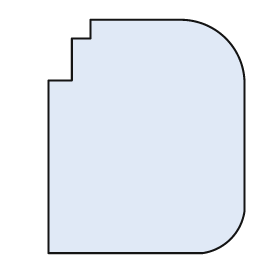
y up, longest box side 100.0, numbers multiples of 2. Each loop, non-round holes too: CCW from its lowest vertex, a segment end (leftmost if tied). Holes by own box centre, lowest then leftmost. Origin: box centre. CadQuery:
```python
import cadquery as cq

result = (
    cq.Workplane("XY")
    .moveTo(-42.0, -50.0)
    .lineTo(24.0, -50.0)
    .threePointArc((36.0, -44.0), (42.0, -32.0))
    .lineTo(42.0, 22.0)
    .threePointArc((34.0, 42.0), (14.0, 50.0))
    .lineTo(-24.0, 50.0)
    .lineTo(-24.0, 42.0)
    .lineTo(-32.0, 42.0)
    .lineTo(-32.0, 24.0)
    .lineTo(-42.0, 24.0)
    .close()
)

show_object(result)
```